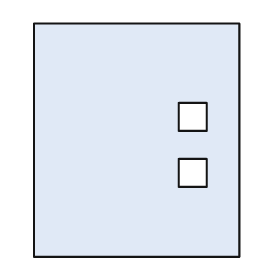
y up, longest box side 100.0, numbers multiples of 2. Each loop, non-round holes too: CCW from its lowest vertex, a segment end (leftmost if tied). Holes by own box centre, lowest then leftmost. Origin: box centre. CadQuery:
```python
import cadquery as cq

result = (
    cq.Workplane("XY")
    .moveTo(-44.0, -50.0)
    .lineTo(44.0, -50.0)
    .lineTo(44.0, 50.0)
    .lineTo(-44.0, 50.0)
    .close()
    .moveTo(18.0, -20.0)
    .lineTo(30.0, -20.0)
    .lineTo(30.0, -8.0)
    .lineTo(18.0, -8.0)
    .close()
    .moveTo(18.0, 4.0)
    .lineTo(30.0, 4.0)
    .lineTo(30.0, 16.0)
    .lineTo(18.0, 16.0)
    .close()
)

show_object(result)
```